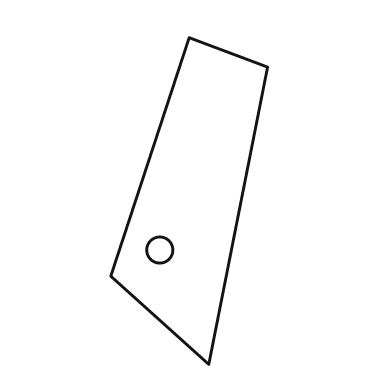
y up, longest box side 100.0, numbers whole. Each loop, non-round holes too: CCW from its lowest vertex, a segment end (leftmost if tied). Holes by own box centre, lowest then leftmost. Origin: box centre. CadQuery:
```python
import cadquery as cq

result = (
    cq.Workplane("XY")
    .moveTo(6.0, -50.0)
    .lineTo(24.0, 41.0)
    .lineTo(0.0, 50.0)
    .lineTo(-24.0, -23.0)
    .close()
    .moveTo(-9.0, -15.0)
    .circle(4.0)
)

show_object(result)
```